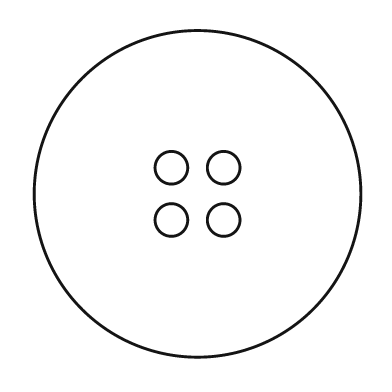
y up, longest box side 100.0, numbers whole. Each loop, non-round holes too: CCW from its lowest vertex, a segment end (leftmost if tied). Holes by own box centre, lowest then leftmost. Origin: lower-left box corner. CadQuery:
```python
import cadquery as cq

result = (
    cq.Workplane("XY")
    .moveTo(50.0, 50.0)
    .circle(50.0)
    .moveTo(42.0, 42.0)
    .circle(5.0)
    .moveTo(58.0, 42.0)
    .circle(5.0)
    .moveTo(42.0, 58.0)
    .circle(5.0)
    .moveTo(58.0, 58.0)
    .circle(5.0)
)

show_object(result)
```